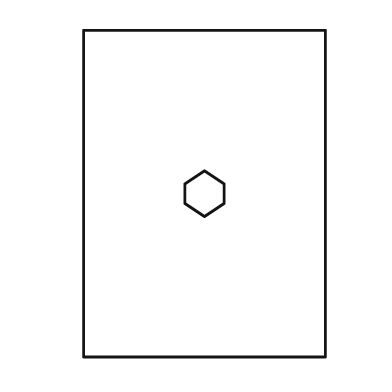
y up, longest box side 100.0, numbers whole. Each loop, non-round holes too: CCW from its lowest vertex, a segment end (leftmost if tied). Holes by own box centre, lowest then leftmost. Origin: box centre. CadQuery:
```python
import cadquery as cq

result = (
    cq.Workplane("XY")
    .moveTo(-37.0, -50.0)
    .lineTo(37.0, -50.0)
    .lineTo(37.0, 50.0)
    .lineTo(-37.0, 50.0)
    .close()
    .moveTo(0.0, -7.0)
    .lineTo(6.0, -3.0)
    .lineTo(6.0, 3.0)
    .lineTo(0.0, 7.0)
    .lineTo(-6.0, 3.0)
    .lineTo(-6.0, -3.0)
    .close()
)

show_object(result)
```